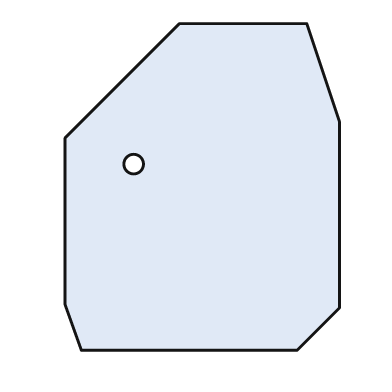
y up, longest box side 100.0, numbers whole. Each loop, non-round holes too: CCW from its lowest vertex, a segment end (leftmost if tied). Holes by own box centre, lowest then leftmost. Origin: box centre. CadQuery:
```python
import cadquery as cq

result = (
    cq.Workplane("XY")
    .moveTo(-37.0, -50.0)
    .lineTo(29.0, -50.0)
    .lineTo(42.0, -37.0)
    .lineTo(42.0, 20.0)
    .lineTo(32.0, 50.0)
    .lineTo(-7.0, 50.0)
    .lineTo(-42.0, 15.0)
    .lineTo(-42.0, -36.0)
    .close()
    .moveTo(-21.0, 7.0)
    .circle(3.0)
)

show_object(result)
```